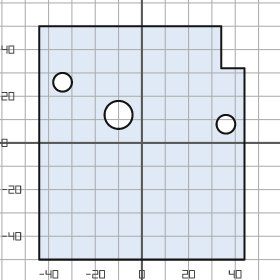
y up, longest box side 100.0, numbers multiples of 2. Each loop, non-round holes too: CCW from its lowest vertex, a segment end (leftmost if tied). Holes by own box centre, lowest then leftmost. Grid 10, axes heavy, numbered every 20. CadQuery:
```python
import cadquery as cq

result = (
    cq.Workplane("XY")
    .moveTo(-44.0, -50.0)
    .lineTo(44.0, -50.0)
    .lineTo(44.0, 32.0)
    .lineTo(34.0, 32.0)
    .lineTo(34.0, 50.0)
    .lineTo(-44.0, 50.0)
    .close()
    .moveTo(36.0, 8.0)
    .circle(4.0)
    .moveTo(-10.0, 12.0)
    .circle(6.0)
    .moveTo(-34.0, 26.0)
    .circle(4.0)
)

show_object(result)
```